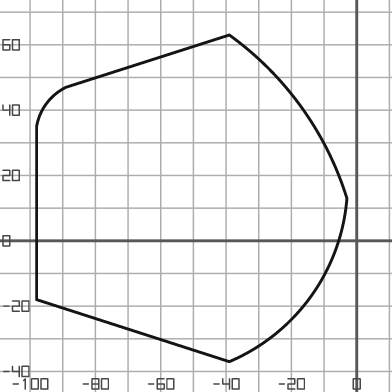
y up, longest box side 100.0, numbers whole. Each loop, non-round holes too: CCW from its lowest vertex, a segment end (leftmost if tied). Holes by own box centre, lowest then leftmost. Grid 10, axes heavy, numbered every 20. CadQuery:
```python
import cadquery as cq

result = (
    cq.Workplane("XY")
    .moveTo(-39.0, -37.0)
    .threePointArc((-14.0, -17.0), (-3.0, 13.0))
    .threePointArc((-17.0, 41.0), (-39.0, 63.0))
    .lineTo(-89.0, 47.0)
    .threePointArc((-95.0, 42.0), (-98.0, 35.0))
    .lineTo(-98.0, -18.0)
    .close()
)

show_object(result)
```